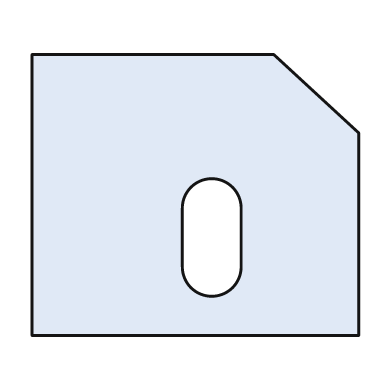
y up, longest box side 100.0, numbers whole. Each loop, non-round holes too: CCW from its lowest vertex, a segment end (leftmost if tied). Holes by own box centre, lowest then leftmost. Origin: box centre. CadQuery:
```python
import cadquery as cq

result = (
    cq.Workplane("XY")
    .moveTo(-50.0, -43.0)
    .lineTo(50.0, -43.0)
    .lineTo(50.0, 19.0)
    .lineTo(24.0, 43.0)
    .lineTo(-50.0, 43.0)
    .close()
    .moveTo(-4.0, -22.0)
    .threePointArc((5.0, -31.0), (14.0, -22.0))
    .lineTo(14.0, -4.0)
    .threePointArc((5.0, 5.0), (-4.0, -4.0))
    .close()
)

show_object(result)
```